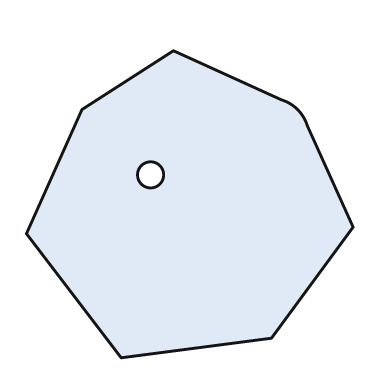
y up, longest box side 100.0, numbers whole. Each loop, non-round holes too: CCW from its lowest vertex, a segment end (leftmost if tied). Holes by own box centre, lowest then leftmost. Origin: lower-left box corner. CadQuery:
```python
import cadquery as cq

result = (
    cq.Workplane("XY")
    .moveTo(29.0, 0.0)
    .lineTo(75.0, 6.0)
    .lineTo(100.0, 40.0)
    .lineTo(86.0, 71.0)
    .threePointArc((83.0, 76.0), (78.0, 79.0))
    .lineTo(45.0, 94.0)
    .lineTo(17.0, 76.0)
    .lineTo(0.0, 38.0)
    .close()
    .moveTo(38.0, 56.0)
    .circle(4.0)
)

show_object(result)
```